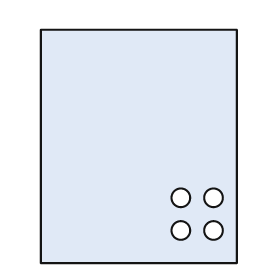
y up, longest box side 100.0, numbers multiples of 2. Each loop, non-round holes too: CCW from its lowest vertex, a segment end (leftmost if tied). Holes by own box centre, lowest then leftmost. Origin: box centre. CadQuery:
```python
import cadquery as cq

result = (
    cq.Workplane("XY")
    .moveTo(-42.0, -50.0)
    .lineTo(42.0, -50.0)
    .lineTo(42.0, 50.0)
    .lineTo(-42.0, 50.0)
    .close()
    .moveTo(18.0, -36.0)
    .circle(4.0)
    .moveTo(32.0, -36.0)
    .circle(4.0)
    .moveTo(18.0, -22.0)
    .circle(4.0)
    .moveTo(32.0, -22.0)
    .circle(4.0)
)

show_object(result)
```